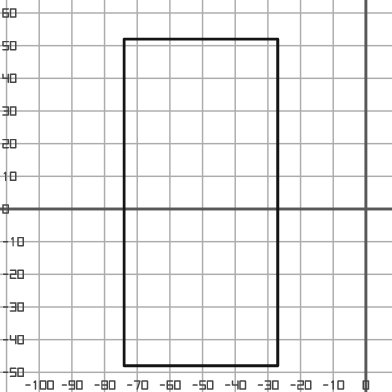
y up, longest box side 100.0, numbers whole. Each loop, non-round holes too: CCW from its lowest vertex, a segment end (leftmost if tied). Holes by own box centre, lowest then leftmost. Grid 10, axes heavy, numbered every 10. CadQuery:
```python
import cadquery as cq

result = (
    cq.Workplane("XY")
    .moveTo(-74.0, -48.0)
    .lineTo(-27.0, -48.0)
    .lineTo(-27.0, 52.0)
    .lineTo(-74.0, 52.0)
    .close()
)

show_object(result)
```